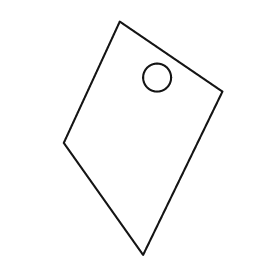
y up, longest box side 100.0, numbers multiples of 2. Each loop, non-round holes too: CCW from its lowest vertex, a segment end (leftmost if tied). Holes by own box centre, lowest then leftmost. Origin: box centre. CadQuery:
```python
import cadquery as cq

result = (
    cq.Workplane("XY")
    .moveTo(0.0, -50.0)
    .lineTo(34.0, 20.0)
    .lineTo(-10.0, 50.0)
    .lineTo(-34.0, -2.0)
    .close()
    .moveTo(6.0, 26.0)
    .circle(6.0)
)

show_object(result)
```